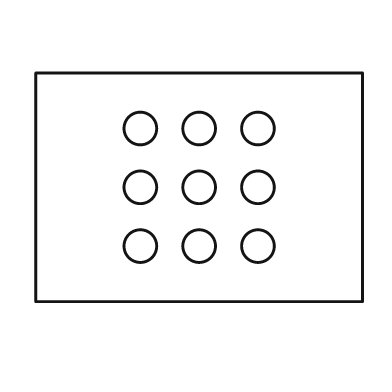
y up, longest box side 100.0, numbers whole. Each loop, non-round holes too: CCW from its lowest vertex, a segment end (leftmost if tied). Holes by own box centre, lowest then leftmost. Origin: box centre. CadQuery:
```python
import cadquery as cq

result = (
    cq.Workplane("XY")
    .moveTo(-50.0, -35.0)
    .lineTo(50.0, -35.0)
    .lineTo(50.0, 35.0)
    .lineTo(-50.0, 35.0)
    .close()
    .moveTo(-18.0, -18.0)
    .circle(5.0)
    .moveTo(0.0, -18.0)
    .circle(5.0)
    .moveTo(18.0, -18.0)
    .circle(5.0)
    .moveTo(-18.0, 0.0)
    .circle(5.0)
    .moveTo(0.0, 0.0)
    .circle(5.0)
    .moveTo(18.0, 0.0)
    .circle(5.0)
    .moveTo(-18.0, 18.0)
    .circle(5.0)
    .moveTo(0.0, 18.0)
    .circle(5.0)
    .moveTo(18.0, 18.0)
    .circle(5.0)
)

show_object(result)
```